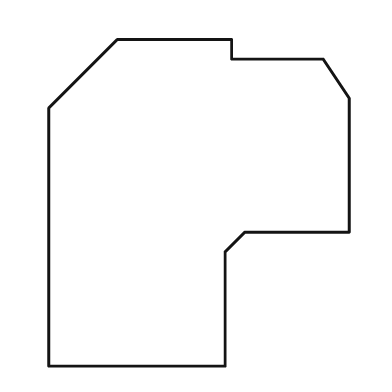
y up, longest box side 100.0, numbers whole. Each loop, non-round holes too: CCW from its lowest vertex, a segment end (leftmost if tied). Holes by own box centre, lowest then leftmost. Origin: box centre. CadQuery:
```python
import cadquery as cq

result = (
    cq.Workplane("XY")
    .moveTo(-46.0, -50.0)
    .lineTo(8.0, -50.0)
    .lineTo(8.0, -15.0)
    .lineTo(14.0, -9.0)
    .lineTo(46.0, -9.0)
    .lineTo(46.0, 32.0)
    .lineTo(38.0, 44.0)
    .lineTo(10.0, 44.0)
    .lineTo(10.0, 50.0)
    .lineTo(-25.0, 50.0)
    .lineTo(-46.0, 29.0)
    .close()
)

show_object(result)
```